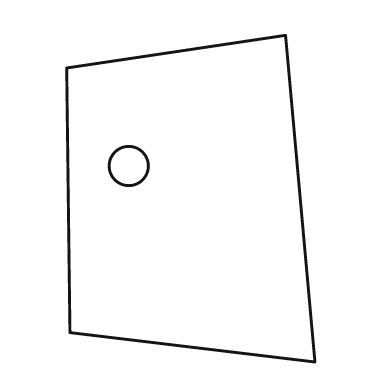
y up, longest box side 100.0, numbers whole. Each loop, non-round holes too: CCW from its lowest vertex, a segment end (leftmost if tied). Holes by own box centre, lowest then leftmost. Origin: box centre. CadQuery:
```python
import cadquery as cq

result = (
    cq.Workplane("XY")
    .moveTo(38.0, -50.0)
    .lineTo(29.0, 50.0)
    .lineTo(-38.0, 40.0)
    .lineTo(-37.0, -41.0)
    .close()
    .moveTo(-19.0, 10.0)
    .circle(6.0)
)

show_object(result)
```